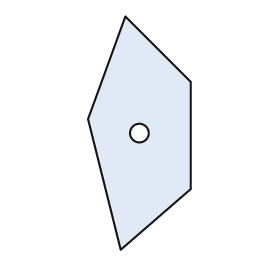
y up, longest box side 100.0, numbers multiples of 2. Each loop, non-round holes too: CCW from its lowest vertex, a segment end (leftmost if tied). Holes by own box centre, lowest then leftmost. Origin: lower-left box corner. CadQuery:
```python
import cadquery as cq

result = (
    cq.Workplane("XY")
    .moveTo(14.0, 0.0)
    .lineTo(44.0, 26.0)
    .lineTo(44.0, 72.0)
    .lineTo(16.0, 100.0)
    .lineTo(0.0, 56.0)
    .close()
    .moveTo(22.0, 50.0)
    .circle(4.0)
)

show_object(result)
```